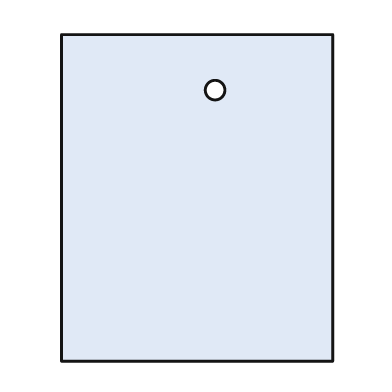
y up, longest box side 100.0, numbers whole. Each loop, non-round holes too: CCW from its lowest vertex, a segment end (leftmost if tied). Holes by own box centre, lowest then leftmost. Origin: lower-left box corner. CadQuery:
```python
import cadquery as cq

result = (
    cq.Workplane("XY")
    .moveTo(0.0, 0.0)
    .lineTo(83.0, 0.0)
    .lineTo(83.0, 100.0)
    .lineTo(0.0, 100.0)
    .close()
    .moveTo(47.0, 83.0)
    .circle(3.0)
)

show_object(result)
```